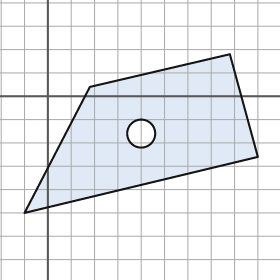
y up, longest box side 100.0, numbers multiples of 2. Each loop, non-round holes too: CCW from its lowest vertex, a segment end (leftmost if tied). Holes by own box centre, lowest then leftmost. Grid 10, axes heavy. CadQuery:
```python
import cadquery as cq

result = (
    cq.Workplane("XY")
    .moveTo(-10.0, -50.0)
    .lineTo(90.0, -26.0)
    .lineTo(78.0, 18.0)
    .lineTo(18.0, 4.0)
    .close()
    .moveTo(40.0, -16.0)
    .circle(6.0)
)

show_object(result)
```